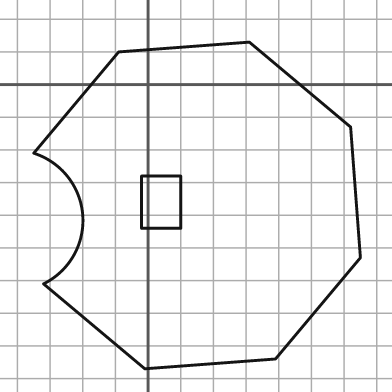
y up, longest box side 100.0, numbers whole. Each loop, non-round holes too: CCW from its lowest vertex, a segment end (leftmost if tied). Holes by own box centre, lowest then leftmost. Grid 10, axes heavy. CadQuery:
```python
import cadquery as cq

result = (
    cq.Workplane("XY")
    .moveTo(-1.0, -87.0)
    .lineTo(39.0, -84.0)
    .lineTo(65.0, -53.0)
    .lineTo(62.0, -13.0)
    .lineTo(31.0, 13.0)
    .lineTo(-9.0, 10.0)
    .lineTo(-35.0, -21.0)
    .threePointArc((-20.0, -40.0), (-32.0, -61.0))
    .close()
    .moveTo(-2.0, -44.0)
    .lineTo(10.0, -44.0)
    .lineTo(10.0, -28.0)
    .lineTo(-2.0, -28.0)
    .close()
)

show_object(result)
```